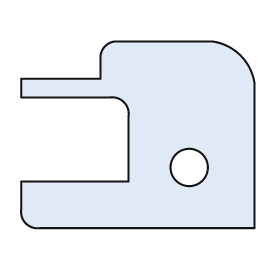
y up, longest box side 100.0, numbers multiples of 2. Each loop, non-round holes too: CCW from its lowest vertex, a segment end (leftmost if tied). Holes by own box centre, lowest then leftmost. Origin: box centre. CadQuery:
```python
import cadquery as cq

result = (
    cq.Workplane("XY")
    .moveTo(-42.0, -40.0)
    .lineTo(50.0, -40.0)
    .lineTo(50.0, 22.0)
    .threePointArc((44.0, 34.0), (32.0, 40.0))
    .lineTo(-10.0, 40.0)
    .threePointArc((-14.0, 38.0), (-16.0, 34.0))
    .lineTo(-16.0, 24.0)
    .lineTo(-50.0, 24.0)
    .lineTo(-50.0, 16.0)
    .lineTo(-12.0, 16.0)
    .threePointArc((-6.0, 14.0), (-4.0, 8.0))
    .lineTo(-4.0, -20.0)
    .lineTo(-50.0, -20.0)
    .lineTo(-50.0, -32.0)
    .threePointArc((-48.0, -38.0), (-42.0, -40.0))
    .close()
    .moveTo(22.0, -14.0)
    .circle(8.0)
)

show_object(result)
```